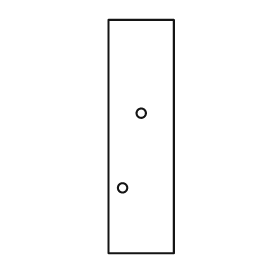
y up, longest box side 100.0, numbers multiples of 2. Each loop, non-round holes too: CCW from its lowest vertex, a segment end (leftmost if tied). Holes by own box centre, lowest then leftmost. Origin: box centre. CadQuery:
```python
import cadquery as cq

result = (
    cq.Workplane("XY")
    .moveTo(-14.0, -50.0)
    .lineTo(14.0, -50.0)
    .lineTo(14.0, 50.0)
    .lineTo(-14.0, 50.0)
    .close()
    .moveTo(-8.0, -22.0)
    .circle(2.0)
    .moveTo(0.0, 10.0)
    .circle(2.0)
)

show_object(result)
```